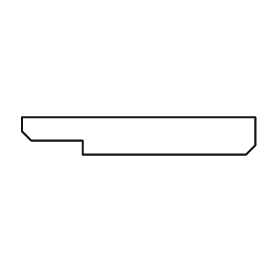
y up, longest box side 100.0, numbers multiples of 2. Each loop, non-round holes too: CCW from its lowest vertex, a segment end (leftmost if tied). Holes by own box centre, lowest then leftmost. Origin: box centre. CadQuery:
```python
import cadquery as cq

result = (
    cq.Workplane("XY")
    .moveTo(-24.0, -8.0)
    .lineTo(46.0, -8.0)
    .lineTo(50.0, -4.0)
    .lineTo(50.0, 8.0)
    .lineTo(-50.0, 8.0)
    .lineTo(-50.0, 2.0)
    .lineTo(-46.0, -2.0)
    .lineTo(-24.0, -2.0)
    .close()
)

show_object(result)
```